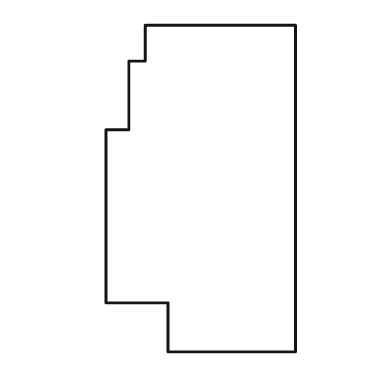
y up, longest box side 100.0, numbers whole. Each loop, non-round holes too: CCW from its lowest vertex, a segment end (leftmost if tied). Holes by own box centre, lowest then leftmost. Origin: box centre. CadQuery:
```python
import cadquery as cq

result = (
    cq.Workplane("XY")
    .moveTo(-10.0, -50.0)
    .lineTo(29.0, -50.0)
    .lineTo(29.0, 50.0)
    .lineTo(-17.0, 50.0)
    .lineTo(-17.0, 39.0)
    .lineTo(-22.0, 39.0)
    .lineTo(-22.0, 18.0)
    .lineTo(-29.0, 18.0)
    .lineTo(-29.0, -35.0)
    .lineTo(-10.0, -35.0)
    .close()
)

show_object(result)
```